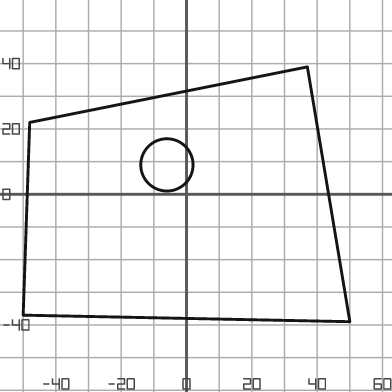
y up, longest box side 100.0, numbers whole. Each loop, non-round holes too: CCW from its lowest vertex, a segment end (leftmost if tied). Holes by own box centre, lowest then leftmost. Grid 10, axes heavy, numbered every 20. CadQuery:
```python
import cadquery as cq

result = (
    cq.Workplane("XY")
    .moveTo(50.0, -39.0)
    .lineTo(37.0, 39.0)
    .lineTo(-48.0, 22.0)
    .lineTo(-50.0, -37.0)
    .close()
    .moveTo(-6.0, 9.0)
    .circle(8.0)
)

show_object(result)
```